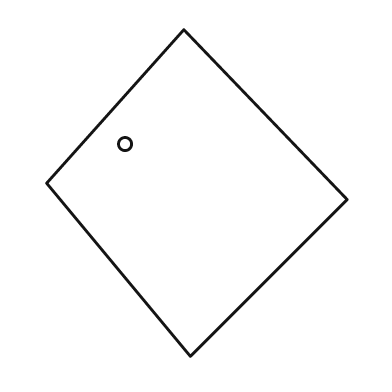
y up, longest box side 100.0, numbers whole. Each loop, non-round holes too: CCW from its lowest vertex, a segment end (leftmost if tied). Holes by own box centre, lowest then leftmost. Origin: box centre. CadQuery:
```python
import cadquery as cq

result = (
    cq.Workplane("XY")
    .moveTo(-2.0, -50.0)
    .lineTo(46.0, -2.0)
    .lineTo(-4.0, 50.0)
    .lineTo(-46.0, 3.0)
    .close()
    .moveTo(-22.0, 15.0)
    .circle(2.0)
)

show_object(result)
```